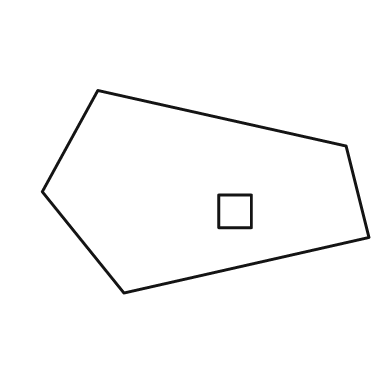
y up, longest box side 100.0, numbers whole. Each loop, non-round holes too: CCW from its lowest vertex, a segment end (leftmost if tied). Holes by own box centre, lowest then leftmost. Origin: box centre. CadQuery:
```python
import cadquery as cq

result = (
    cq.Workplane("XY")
    .moveTo(-25.0, -31.0)
    .lineTo(50.0, -14.0)
    .lineTo(43.0, 14.0)
    .lineTo(-33.0, 31.0)
    .lineTo(-50.0, 0.0)
    .close()
    .moveTo(4.0, -11.0)
    .lineTo(14.0, -11.0)
    .lineTo(14.0, -1.0)
    .lineTo(4.0, -1.0)
    .close()
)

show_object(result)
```